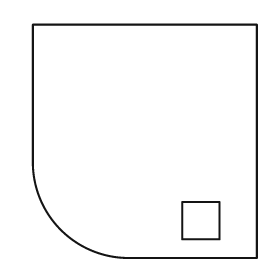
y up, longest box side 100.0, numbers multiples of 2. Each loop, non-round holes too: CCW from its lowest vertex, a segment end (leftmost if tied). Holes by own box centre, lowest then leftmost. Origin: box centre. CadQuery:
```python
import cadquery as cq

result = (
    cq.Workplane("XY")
    .moveTo(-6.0, -50.0)
    .lineTo(48.0, -50.0)
    .lineTo(48.0, 50.0)
    .lineTo(-48.0, 50.0)
    .lineTo(-48.0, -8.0)
    .threePointArc((-36.0, -38.0), (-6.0, -50.0))
    .close()
    .moveTo(16.0, -42.0)
    .lineTo(32.0, -42.0)
    .lineTo(32.0, -26.0)
    .lineTo(16.0, -26.0)
    .close()
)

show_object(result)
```